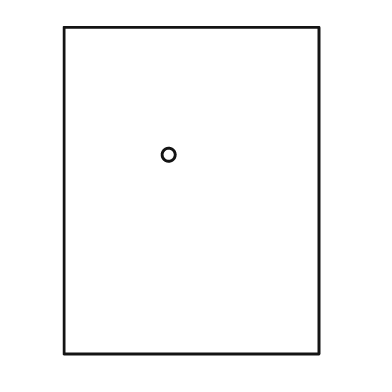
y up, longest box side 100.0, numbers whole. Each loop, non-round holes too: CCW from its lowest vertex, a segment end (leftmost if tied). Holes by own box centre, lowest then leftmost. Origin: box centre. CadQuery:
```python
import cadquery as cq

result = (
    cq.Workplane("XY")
    .moveTo(-39.0, -50.0)
    .lineTo(39.0, -50.0)
    .lineTo(39.0, 50.0)
    .lineTo(-39.0, 50.0)
    .close()
    .moveTo(-7.0, 11.0)
    .circle(2.0)
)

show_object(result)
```